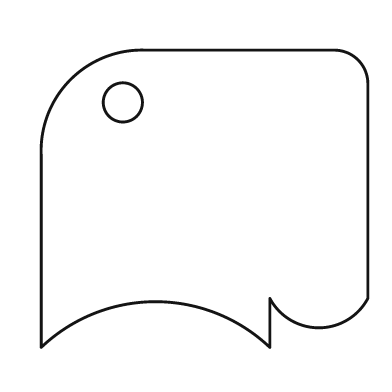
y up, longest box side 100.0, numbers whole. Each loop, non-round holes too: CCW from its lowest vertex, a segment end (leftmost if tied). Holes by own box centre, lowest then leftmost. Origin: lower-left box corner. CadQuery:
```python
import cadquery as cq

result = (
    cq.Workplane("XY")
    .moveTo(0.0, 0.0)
    .threePointArc((35.0, 14.0), (70.0, 0.0))
    .lineTo(70.0, 15.0)
    .threePointArc((85.0, 6.0), (100.0, 15.0))
    .lineTo(100.0, 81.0)
    .threePointArc((97.0, 88.0), (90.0, 91.0))
    .lineTo(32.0, 91.0)
    .threePointArc((9.0, 82.0), (0.0, 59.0))
    .close()
    .moveTo(25.0, 75.0)
    .circle(6.0)
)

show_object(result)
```